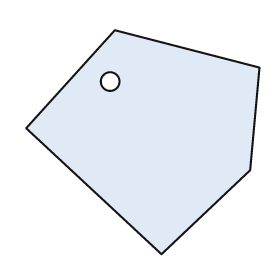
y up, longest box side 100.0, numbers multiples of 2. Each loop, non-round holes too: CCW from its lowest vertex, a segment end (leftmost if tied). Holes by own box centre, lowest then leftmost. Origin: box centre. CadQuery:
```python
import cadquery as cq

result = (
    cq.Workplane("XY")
    .moveTo(8.0, -48.0)
    .lineTo(46.0, -12.0)
    .lineTo(50.0, 32.0)
    .lineTo(-12.0, 48.0)
    .lineTo(-50.0, 6.0)
    .close()
    .moveTo(-14.0, 26.0)
    .circle(4.0)
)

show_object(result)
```